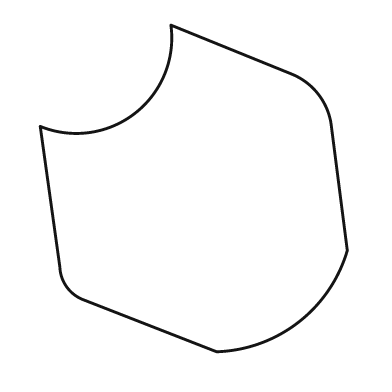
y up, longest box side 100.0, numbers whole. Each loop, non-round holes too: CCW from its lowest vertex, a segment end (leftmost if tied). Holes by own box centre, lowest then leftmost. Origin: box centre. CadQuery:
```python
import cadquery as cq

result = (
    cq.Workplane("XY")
    .moveTo(7.0, -50.0)
    .threePointArc((32.0, -41.0), (47.0, -19.0))
    .lineTo(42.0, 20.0)
    .threePointArc((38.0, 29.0), (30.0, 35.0))
    .lineTo(-7.0, 50.0)
    .threePointArc((-18.0, 23.0), (-47.0, 19.0))
    .lineTo(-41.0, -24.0)
    .threePointArc((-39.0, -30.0), (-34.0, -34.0))
    .close()
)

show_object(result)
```